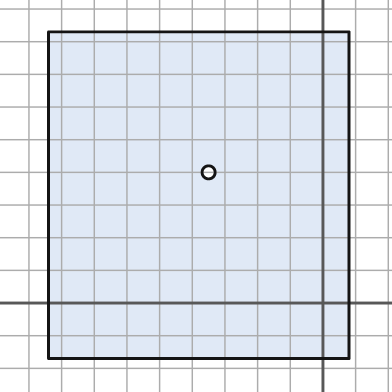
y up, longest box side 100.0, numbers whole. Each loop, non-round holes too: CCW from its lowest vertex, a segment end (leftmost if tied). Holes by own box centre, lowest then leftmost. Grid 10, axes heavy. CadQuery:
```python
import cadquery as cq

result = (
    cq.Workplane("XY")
    .moveTo(-84.0, -17.0)
    .lineTo(8.0, -17.0)
    .lineTo(8.0, 83.0)
    .lineTo(-84.0, 83.0)
    .close()
    .moveTo(-35.0, 40.0)
    .circle(2.0)
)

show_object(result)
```